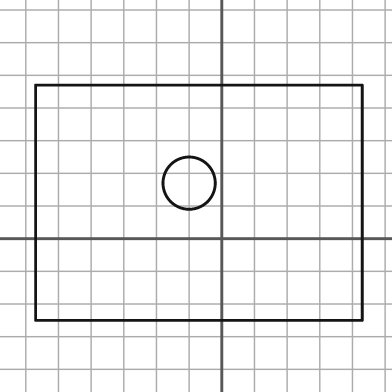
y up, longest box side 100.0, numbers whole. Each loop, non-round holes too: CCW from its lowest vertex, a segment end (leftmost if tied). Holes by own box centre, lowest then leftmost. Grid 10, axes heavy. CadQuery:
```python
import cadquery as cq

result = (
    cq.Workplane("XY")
    .moveTo(-57.0, -25.0)
    .lineTo(43.0, -25.0)
    .lineTo(43.0, 47.0)
    .lineTo(-57.0, 47.0)
    .close()
    .moveTo(-10.0, 17.0)
    .circle(8.0)
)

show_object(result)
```